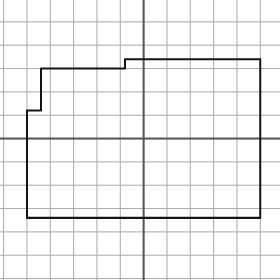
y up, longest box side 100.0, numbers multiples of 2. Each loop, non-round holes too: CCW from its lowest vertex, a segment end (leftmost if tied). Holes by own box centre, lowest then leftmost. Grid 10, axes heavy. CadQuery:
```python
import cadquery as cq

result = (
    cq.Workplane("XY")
    .moveTo(-50.0, -34.0)
    .lineTo(50.0, -34.0)
    .lineTo(50.0, 34.0)
    .lineTo(-8.0, 34.0)
    .lineTo(-8.0, 30.0)
    .lineTo(-44.0, 30.0)
    .lineTo(-44.0, 12.0)
    .lineTo(-50.0, 12.0)
    .close()
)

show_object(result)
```